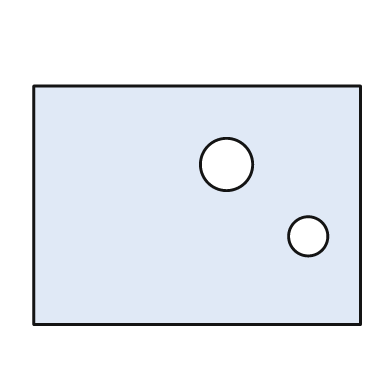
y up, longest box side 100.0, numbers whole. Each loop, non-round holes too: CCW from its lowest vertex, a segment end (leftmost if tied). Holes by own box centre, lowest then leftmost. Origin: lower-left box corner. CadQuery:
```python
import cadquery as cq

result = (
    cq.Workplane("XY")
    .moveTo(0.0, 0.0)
    .lineTo(100.0, 0.0)
    .lineTo(100.0, 73.0)
    .lineTo(0.0, 73.0)
    .close()
    .moveTo(84.0, 27.0)
    .circle(6.0)
    .moveTo(59.0, 49.0)
    .circle(8.0)
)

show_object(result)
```